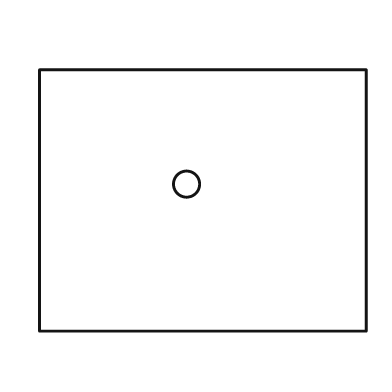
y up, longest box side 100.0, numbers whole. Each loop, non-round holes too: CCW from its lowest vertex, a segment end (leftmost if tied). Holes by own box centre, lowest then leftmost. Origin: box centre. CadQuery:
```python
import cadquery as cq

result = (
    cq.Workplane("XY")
    .moveTo(-50.0, -40.0)
    .lineTo(50.0, -40.0)
    .lineTo(50.0, 40.0)
    .lineTo(-50.0, 40.0)
    .close()
    .moveTo(-5.0, 5.0)
    .circle(4.0)
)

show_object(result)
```